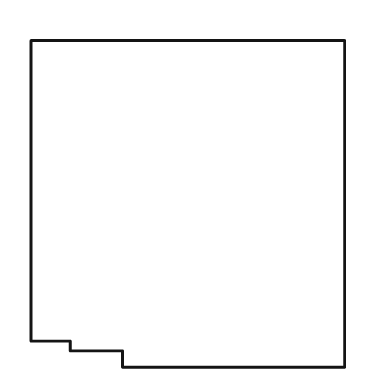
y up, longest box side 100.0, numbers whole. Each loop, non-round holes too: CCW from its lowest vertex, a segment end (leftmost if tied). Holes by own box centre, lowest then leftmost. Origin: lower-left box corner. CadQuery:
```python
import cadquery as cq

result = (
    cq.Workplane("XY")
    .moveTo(28.0, 0.0)
    .lineTo(96.0, 0.0)
    .lineTo(96.0, 100.0)
    .lineTo(0.0, 100.0)
    .lineTo(0.0, 8.0)
    .lineTo(12.0, 8.0)
    .lineTo(12.0, 5.0)
    .lineTo(28.0, 5.0)
    .close()
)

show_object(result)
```